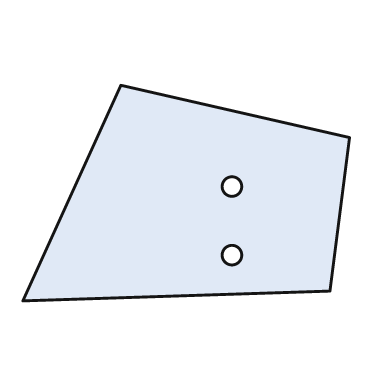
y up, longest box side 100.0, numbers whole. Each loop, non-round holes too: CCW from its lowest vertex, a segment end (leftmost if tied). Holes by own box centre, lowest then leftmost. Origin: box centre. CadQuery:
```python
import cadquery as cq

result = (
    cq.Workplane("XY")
    .moveTo(-50.0, -33.0)
    .lineTo(44.0, -30.0)
    .lineTo(50.0, 17.0)
    .lineTo(-20.0, 33.0)
    .close()
    .moveTo(14.0, -19.0)
    .circle(3.0)
    .moveTo(14.0, 2.0)
    .circle(3.0)
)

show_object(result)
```